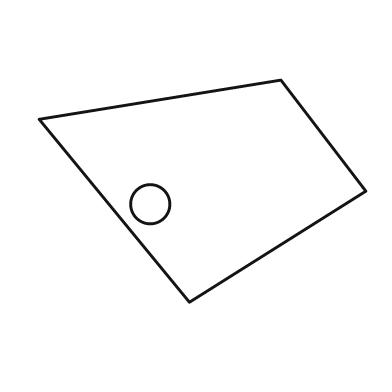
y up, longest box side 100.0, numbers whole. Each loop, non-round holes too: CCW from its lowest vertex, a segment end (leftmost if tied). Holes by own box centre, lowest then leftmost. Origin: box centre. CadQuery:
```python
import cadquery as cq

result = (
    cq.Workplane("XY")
    .moveTo(-4.0, -34.0)
    .lineTo(50.0, 0.0)
    .lineTo(24.0, 34.0)
    .lineTo(-50.0, 22.0)
    .close()
    .moveTo(-16.0, -4.0)
    .circle(6.0)
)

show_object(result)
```